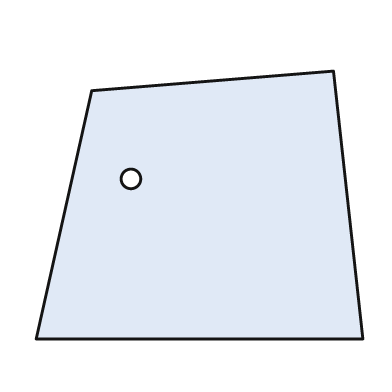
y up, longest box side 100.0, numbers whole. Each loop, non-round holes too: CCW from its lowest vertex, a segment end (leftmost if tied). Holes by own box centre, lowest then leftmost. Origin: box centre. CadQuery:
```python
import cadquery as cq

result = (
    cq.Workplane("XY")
    .moveTo(-50.0, -41.0)
    .lineTo(50.0, -41.0)
    .lineTo(41.0, 41.0)
    .lineTo(-33.0, 35.0)
    .close()
    .moveTo(-21.0, 8.0)
    .circle(3.0)
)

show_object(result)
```